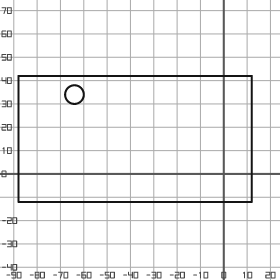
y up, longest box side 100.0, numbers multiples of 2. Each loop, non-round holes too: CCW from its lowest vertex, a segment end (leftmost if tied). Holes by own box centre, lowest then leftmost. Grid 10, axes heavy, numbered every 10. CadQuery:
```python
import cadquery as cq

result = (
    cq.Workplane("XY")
    .moveTo(-88.0, -12.0)
    .lineTo(12.0, -12.0)
    .lineTo(12.0, 42.0)
    .lineTo(-88.0, 42.0)
    .close()
    .moveTo(-64.0, 34.0)
    .circle(4.0)
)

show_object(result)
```